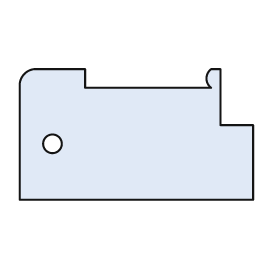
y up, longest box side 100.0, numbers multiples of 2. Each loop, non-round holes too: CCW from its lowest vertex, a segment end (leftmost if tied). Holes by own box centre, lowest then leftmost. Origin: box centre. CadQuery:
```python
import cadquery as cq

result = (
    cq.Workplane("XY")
    .moveTo(-50.0, -28.0)
    .lineTo(50.0, -28.0)
    .lineTo(50.0, 4.0)
    .lineTo(36.0, 4.0)
    .lineTo(36.0, 28.0)
    .lineTo(32.0, 28.0)
    .threePointArc((30.0, 24.0), (32.0, 20.0))
    .lineTo(-22.0, 20.0)
    .lineTo(-22.0, 28.0)
    .lineTo(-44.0, 28.0)
    .threePointArc((-48.0, 26.0), (-50.0, 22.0))
    .close()
    .moveTo(-36.0, -4.0)
    .circle(4.0)
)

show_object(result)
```